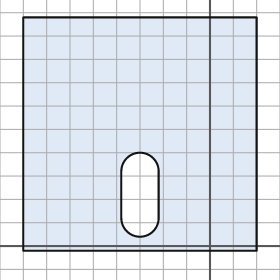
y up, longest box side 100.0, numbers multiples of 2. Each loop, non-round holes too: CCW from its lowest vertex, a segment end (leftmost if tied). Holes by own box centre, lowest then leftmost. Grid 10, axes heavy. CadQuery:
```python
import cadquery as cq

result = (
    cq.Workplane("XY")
    .moveTo(-80.0, -2.0)
    .lineTo(20.0, -2.0)
    .lineTo(20.0, 98.0)
    .lineTo(-80.0, 98.0)
    .close()
    .moveTo(-38.0, 12.0)
    .threePointArc((-30.0, 4.0), (-22.0, 12.0))
    .lineTo(-22.0, 32.0)
    .threePointArc((-30.0, 40.0), (-38.0, 32.0))
    .close()
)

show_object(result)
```